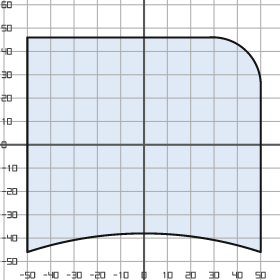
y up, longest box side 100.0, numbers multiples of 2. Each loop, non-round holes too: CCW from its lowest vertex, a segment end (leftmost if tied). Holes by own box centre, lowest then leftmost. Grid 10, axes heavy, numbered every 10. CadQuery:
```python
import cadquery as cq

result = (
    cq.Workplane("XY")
    .moveTo(-50.0, -46.0)
    .threePointArc((0.0, -38.0), (50.0, -46.0))
    .lineTo(50.0, 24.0)
    .threePointArc((44.0, 40.0), (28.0, 46.0))
    .lineTo(-50.0, 46.0)
    .close()
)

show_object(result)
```